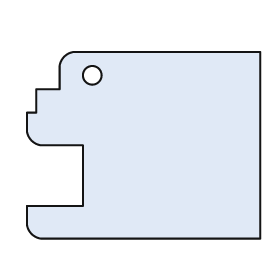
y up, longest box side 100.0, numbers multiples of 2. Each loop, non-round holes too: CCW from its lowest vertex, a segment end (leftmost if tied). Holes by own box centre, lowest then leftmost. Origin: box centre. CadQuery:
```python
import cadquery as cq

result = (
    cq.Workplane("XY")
    .moveTo(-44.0, -40.0)
    .lineTo(50.0, -40.0)
    .lineTo(50.0, 40.0)
    .lineTo(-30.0, 40.0)
    .threePointArc((-34.0, 38.0), (-36.0, 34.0))
    .lineTo(-36.0, 24.0)
    .lineTo(-46.0, 24.0)
    .lineTo(-46.0, 14.0)
    .lineTo(-50.0, 14.0)
    .lineTo(-50.0, 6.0)
    .threePointArc((-48.0, 2.0), (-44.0, 0.0))
    .lineTo(-26.0, 0.0)
    .lineTo(-26.0, -26.0)
    .lineTo(-50.0, -26.0)
    .lineTo(-50.0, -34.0)
    .threePointArc((-48.0, -38.0), (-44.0, -40.0))
    .close()
    .moveTo(-22.0, 30.0)
    .circle(4.0)
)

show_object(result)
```